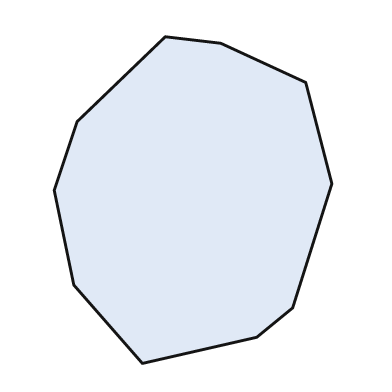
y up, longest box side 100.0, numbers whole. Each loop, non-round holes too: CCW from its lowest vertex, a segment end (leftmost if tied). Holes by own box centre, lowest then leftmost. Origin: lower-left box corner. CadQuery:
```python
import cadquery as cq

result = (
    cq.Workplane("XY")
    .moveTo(27.0, 0.0)
    .lineTo(62.0, 8.0)
    .lineTo(73.0, 17.0)
    .lineTo(85.0, 55.0)
    .lineTo(77.0, 86.0)
    .lineTo(51.0, 98.0)
    .lineTo(34.0, 100.0)
    .lineTo(7.0, 74.0)
    .lineTo(0.0, 53.0)
    .lineTo(6.0, 24.0)
    .close()
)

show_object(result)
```